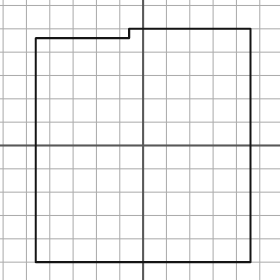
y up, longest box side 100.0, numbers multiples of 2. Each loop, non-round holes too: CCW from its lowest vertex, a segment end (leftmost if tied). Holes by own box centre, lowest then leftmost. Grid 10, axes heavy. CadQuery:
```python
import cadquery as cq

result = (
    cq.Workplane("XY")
    .moveTo(-46.0, -50.0)
    .lineTo(46.0, -50.0)
    .lineTo(46.0, 50.0)
    .lineTo(-6.0, 50.0)
    .lineTo(-6.0, 46.0)
    .lineTo(-46.0, 46.0)
    .close()
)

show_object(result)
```